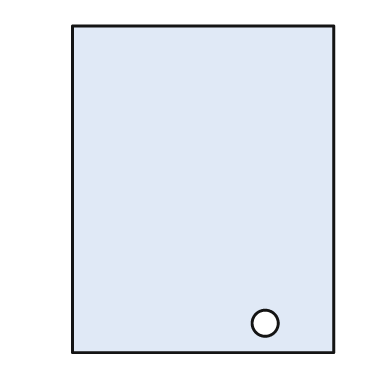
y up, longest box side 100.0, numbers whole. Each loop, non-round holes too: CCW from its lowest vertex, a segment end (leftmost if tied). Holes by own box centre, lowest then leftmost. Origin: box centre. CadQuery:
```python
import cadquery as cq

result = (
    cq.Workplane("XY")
    .moveTo(-40.0, -50.0)
    .lineTo(40.0, -50.0)
    .lineTo(40.0, 50.0)
    .lineTo(-40.0, 50.0)
    .close()
    .moveTo(19.0, -41.0)
    .circle(4.0)
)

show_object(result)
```